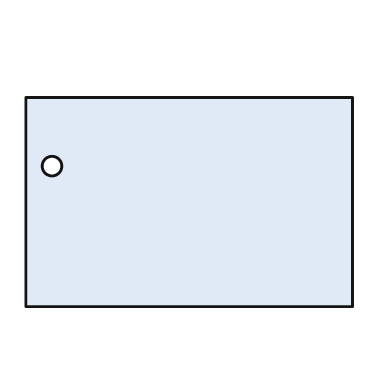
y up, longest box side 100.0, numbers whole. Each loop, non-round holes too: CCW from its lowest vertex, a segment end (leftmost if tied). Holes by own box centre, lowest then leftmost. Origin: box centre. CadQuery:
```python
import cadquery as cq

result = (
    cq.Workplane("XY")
    .moveTo(-50.0, -32.0)
    .lineTo(50.0, -32.0)
    .lineTo(50.0, 32.0)
    .lineTo(-50.0, 32.0)
    .close()
    .moveTo(-42.0, 11.0)
    .circle(3.0)
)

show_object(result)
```